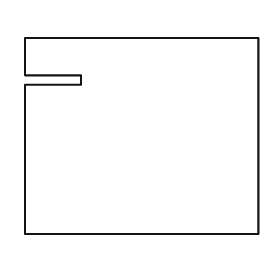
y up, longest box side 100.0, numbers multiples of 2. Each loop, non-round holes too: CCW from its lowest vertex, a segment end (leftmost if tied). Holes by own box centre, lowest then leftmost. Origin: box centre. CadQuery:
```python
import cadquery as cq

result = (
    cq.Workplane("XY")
    .moveTo(-50.0, -42.0)
    .lineTo(50.0, -42.0)
    .lineTo(50.0, 42.0)
    .lineTo(-50.0, 42.0)
    .lineTo(-50.0, 26.0)
    .lineTo(-26.0, 26.0)
    .lineTo(-26.0, 22.0)
    .lineTo(-50.0, 22.0)
    .close()
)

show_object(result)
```